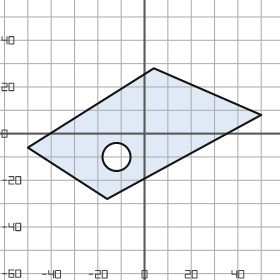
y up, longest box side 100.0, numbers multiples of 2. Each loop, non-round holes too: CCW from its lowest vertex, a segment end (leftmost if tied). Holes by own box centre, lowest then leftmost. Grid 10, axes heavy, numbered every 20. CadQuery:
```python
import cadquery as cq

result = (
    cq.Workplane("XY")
    .moveTo(-16.0, -28.0)
    .lineTo(50.0, 8.0)
    .lineTo(4.0, 28.0)
    .lineTo(-50.0, -6.0)
    .close()
    .moveTo(-12.0, -10.0)
    .circle(6.0)
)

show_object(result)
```